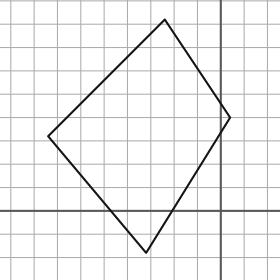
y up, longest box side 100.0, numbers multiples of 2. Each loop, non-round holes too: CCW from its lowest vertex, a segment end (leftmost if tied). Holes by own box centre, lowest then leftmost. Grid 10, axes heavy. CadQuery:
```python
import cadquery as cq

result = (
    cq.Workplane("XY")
    .moveTo(-32.0, -18.0)
    .lineTo(4.0, 40.0)
    .lineTo(-24.0, 82.0)
    .lineTo(-74.0, 32.0)
    .close()
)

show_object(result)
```